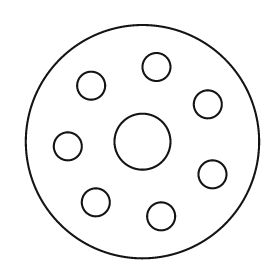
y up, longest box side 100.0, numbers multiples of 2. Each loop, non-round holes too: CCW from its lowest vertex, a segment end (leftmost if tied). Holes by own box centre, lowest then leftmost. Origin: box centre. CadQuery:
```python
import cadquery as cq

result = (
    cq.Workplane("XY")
    .moveTo(0.0, 0.0)
    .circle(50.0)
    .moveTo(8.0, -32.0)
    .circle(6.0)
    .moveTo(-20.0, -26.0)
    .circle(6.0)
    .moveTo(30.0, -14.0)
    .circle(6.0)
    .moveTo(-32.0, -2.0)
    .circle(6.0)
    .moveTo(0.0, 0.0)
    .circle(12.0)
    .moveTo(28.0, 16.0)
    .circle(6.0)
    .moveTo(-22.0, 24.0)
    .circle(6.0)
    .moveTo(6.0, 32.0)
    .circle(6.0)
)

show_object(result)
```